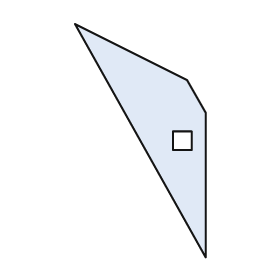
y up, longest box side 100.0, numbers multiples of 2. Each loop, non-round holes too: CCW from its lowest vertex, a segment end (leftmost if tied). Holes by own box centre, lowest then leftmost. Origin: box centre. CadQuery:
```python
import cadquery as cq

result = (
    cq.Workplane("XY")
    .moveTo(28.0, -50.0)
    .lineTo(28.0, 12.0)
    .lineTo(20.0, 26.0)
    .lineTo(-28.0, 50.0)
    .close()
    .moveTo(14.0, -4.0)
    .lineTo(22.0, -4.0)
    .lineTo(22.0, 4.0)
    .lineTo(14.0, 4.0)
    .close()
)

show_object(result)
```